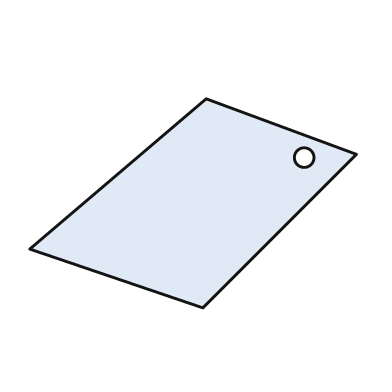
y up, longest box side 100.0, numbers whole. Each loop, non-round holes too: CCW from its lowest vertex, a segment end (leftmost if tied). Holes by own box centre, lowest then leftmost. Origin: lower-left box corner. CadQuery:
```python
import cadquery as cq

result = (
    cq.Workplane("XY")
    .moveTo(53.0, 0.0)
    .lineTo(100.0, 47.0)
    .lineTo(54.0, 64.0)
    .lineTo(0.0, 18.0)
    .close()
    .moveTo(84.0, 46.0)
    .circle(3.0)
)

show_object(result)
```